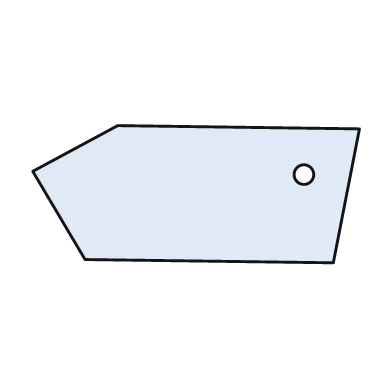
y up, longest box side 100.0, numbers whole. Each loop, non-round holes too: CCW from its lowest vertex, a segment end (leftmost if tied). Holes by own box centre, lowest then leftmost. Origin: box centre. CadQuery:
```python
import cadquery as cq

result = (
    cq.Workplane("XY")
    .moveTo(42.0, -21.0)
    .lineTo(50.0, 20.0)
    .lineTo(-24.0, 21.0)
    .lineTo(-50.0, 7.0)
    .lineTo(-34.0, -20.0)
    .close()
    .moveTo(33.0, 6.0)
    .circle(3.0)
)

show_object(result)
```